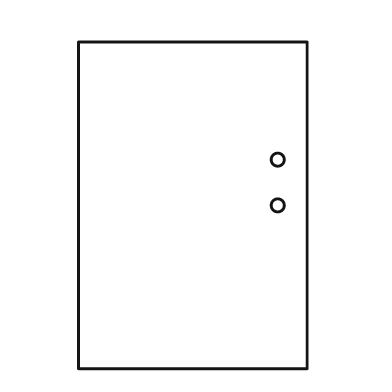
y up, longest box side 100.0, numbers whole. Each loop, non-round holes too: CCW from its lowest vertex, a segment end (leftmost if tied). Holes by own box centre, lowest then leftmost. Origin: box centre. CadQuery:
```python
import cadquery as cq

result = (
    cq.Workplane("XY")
    .moveTo(-35.0, -50.0)
    .lineTo(35.0, -50.0)
    .lineTo(35.0, 50.0)
    .lineTo(-35.0, 50.0)
    .close()
    .moveTo(26.0, 0.0)
    .circle(2.0)
    .moveTo(26.0, 14.0)
    .circle(2.0)
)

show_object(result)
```